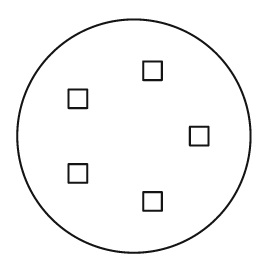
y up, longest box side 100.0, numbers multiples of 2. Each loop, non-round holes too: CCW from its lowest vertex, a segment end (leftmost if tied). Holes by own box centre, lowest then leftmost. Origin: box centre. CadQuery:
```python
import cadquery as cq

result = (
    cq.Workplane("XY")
    .moveTo(0.0, 0.0)
    .circle(50.0)
    .moveTo(4.0, -32.0)
    .lineTo(12.0, -32.0)
    .lineTo(12.0, -24.0)
    .lineTo(4.0, -24.0)
    .close()
    .moveTo(-28.0, -20.0)
    .lineTo(-20.0, -20.0)
    .lineTo(-20.0, -12.0)
    .lineTo(-28.0, -12.0)
    .close()
    .moveTo(24.0, -4.0)
    .lineTo(32.0, -4.0)
    .lineTo(32.0, 4.0)
    .lineTo(24.0, 4.0)
    .close()
    .moveTo(-28.0, 12.0)
    .lineTo(-20.0, 12.0)
    .lineTo(-20.0, 20.0)
    .lineTo(-28.0, 20.0)
    .close()
    .moveTo(4.0, 24.0)
    .lineTo(12.0, 24.0)
    .lineTo(12.0, 32.0)
    .lineTo(4.0, 32.0)
    .close()
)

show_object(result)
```